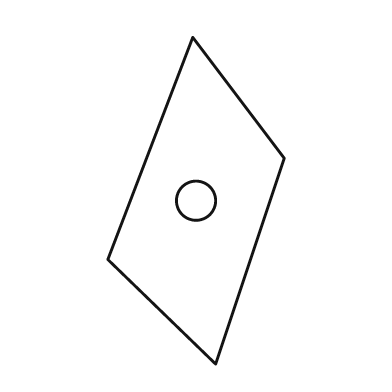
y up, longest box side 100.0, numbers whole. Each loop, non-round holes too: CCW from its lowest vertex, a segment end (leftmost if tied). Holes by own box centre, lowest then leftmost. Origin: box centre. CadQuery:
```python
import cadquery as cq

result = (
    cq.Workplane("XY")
    .moveTo(6.0, -50.0)
    .lineTo(27.0, 13.0)
    .lineTo(-1.0, 50.0)
    .lineTo(-27.0, -18.0)
    .close()
    .moveTo(0.0, 0.0)
    .circle(6.0)
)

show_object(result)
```